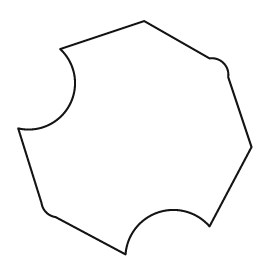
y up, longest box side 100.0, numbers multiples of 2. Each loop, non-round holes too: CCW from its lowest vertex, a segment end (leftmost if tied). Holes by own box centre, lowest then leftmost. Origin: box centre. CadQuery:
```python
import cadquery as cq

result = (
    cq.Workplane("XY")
    .moveTo(-4.0, -50.0)
    .threePointArc((10.0, -32.0), (32.0, -38.0))
    .lineTo(50.0, -4.0)
    .lineTo(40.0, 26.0)
    .threePointArc((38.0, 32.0), (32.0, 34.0))
    .lineTo(4.0, 50.0)
    .lineTo(-32.0, 38.0)
    .threePointArc((-28.0, 14.0), (-50.0, 4.0))
    .lineTo(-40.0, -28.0)
    .threePointArc((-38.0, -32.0), (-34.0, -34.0))
    .close()
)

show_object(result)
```